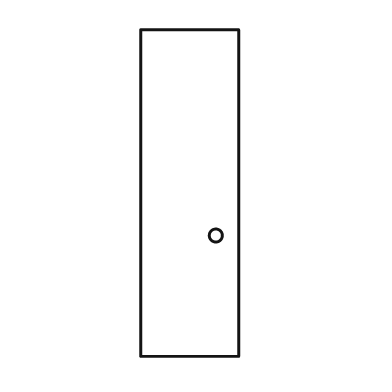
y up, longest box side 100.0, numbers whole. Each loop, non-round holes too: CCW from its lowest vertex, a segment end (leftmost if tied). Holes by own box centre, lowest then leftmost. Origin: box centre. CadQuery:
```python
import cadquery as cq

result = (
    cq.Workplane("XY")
    .moveTo(-15.0, -50.0)
    .lineTo(15.0, -50.0)
    .lineTo(15.0, 50.0)
    .lineTo(-15.0, 50.0)
    .close()
    .moveTo(8.0, -13.0)
    .circle(2.0)
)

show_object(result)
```